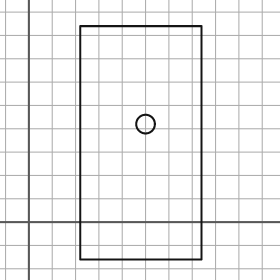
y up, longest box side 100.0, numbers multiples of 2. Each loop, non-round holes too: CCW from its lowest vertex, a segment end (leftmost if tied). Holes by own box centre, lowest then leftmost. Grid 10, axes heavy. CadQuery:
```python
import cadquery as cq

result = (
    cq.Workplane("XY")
    .moveTo(22.0, -16.0)
    .lineTo(74.0, -16.0)
    .lineTo(74.0, 84.0)
    .lineTo(22.0, 84.0)
    .close()
    .moveTo(50.0, 42.0)
    .circle(4.0)
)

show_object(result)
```